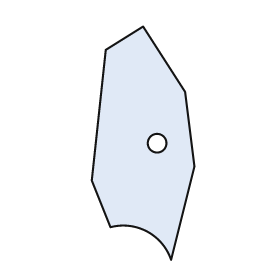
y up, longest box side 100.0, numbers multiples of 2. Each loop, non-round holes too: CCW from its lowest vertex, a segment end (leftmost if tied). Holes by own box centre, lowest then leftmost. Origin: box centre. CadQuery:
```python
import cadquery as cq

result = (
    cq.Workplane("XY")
    .moveTo(12.0, -50.0)
    .lineTo(22.0, -10.0)
    .lineTo(18.0, 22.0)
    .lineTo(0.0, 50.0)
    .lineTo(-16.0, 40.0)
    .lineTo(-22.0, -16.0)
    .lineTo(-14.0, -36.0)
    .threePointArc((2.0, -38.0), (12.0, -50.0))
    .close()
    .moveTo(6.0, 0.0)
    .circle(4.0)
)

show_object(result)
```